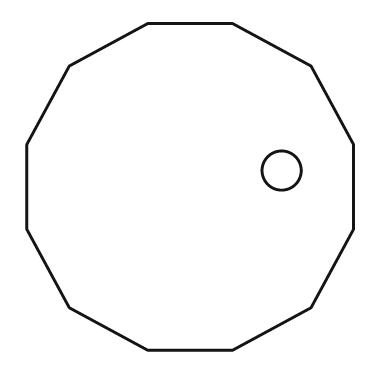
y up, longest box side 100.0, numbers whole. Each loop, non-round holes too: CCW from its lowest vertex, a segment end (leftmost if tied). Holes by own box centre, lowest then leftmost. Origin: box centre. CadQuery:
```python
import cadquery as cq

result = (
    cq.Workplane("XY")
    .moveTo(-13.0, -50.0)
    .lineTo(13.0, -50.0)
    .lineTo(37.0, -37.0)
    .lineTo(50.0, -13.0)
    .lineTo(50.0, 13.0)
    .lineTo(37.0, 37.0)
    .lineTo(13.0, 50.0)
    .lineTo(-13.0, 50.0)
    .lineTo(-37.0, 37.0)
    .lineTo(-50.0, 13.0)
    .lineTo(-50.0, -13.0)
    .lineTo(-37.0, -37.0)
    .close()
    .moveTo(28.0, 5.0)
    .circle(6.0)
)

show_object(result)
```